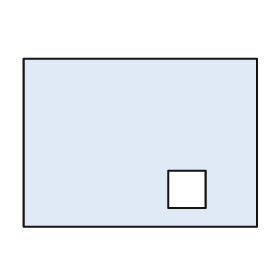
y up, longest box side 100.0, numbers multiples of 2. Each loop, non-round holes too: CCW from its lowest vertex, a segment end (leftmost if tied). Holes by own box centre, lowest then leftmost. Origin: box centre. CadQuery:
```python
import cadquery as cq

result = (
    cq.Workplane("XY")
    .moveTo(-50.0, -36.0)
    .lineTo(50.0, -36.0)
    .lineTo(50.0, 36.0)
    .lineTo(-50.0, 36.0)
    .close()
    .moveTo(12.0, -28.0)
    .lineTo(28.0, -28.0)
    .lineTo(28.0, -12.0)
    .lineTo(12.0, -12.0)
    .close()
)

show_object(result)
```